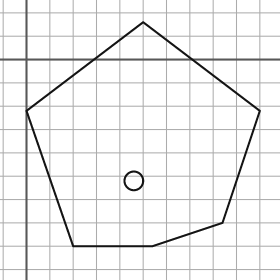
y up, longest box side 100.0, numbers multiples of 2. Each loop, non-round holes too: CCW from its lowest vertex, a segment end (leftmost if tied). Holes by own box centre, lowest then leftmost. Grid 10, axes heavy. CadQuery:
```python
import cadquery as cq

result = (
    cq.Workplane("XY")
    .moveTo(20.0, -80.0)
    .lineTo(54.0, -80.0)
    .lineTo(84.0, -70.0)
    .lineTo(100.0, -22.0)
    .lineTo(50.0, 16.0)
    .lineTo(0.0, -22.0)
    .close()
    .moveTo(46.0, -52.0)
    .circle(4.0)
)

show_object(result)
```